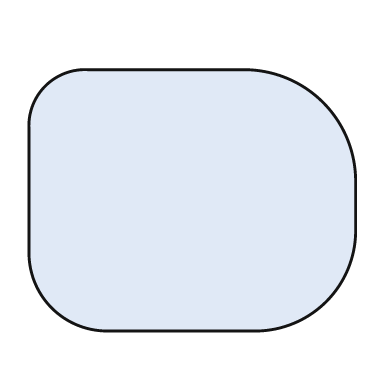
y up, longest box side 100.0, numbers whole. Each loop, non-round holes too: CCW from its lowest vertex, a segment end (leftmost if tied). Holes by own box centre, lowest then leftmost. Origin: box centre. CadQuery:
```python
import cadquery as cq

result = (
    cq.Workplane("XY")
    .moveTo(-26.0, -40.0)
    .lineTo(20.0, -40.0)
    .threePointArc((41.0, -31.0), (50.0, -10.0))
    .lineTo(50.0, 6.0)
    .threePointArc((40.0, 30.0), (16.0, 40.0))
    .lineTo(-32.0, 40.0)
    .threePointArc((-45.0, 35.0), (-50.0, 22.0))
    .lineTo(-50.0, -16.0)
    .threePointArc((-43.0, -33.0), (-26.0, -40.0))
    .close()
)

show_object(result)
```